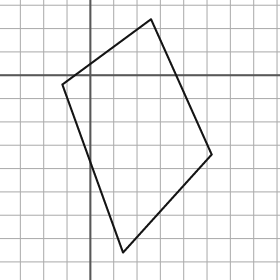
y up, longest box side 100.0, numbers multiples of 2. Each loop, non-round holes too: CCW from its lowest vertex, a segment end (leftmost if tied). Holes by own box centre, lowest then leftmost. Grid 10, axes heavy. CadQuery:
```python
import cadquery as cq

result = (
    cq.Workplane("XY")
    .moveTo(14.0, -76.0)
    .lineTo(52.0, -34.0)
    .lineTo(26.0, 24.0)
    .lineTo(-12.0, -4.0)
    .close()
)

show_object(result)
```